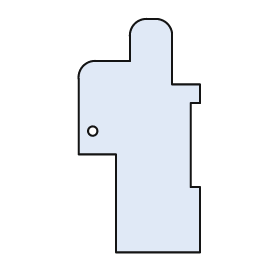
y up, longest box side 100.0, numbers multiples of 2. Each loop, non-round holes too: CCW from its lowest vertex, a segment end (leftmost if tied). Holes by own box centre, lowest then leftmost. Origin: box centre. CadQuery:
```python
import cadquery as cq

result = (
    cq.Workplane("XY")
    .moveTo(-10.0, -50.0)
    .lineTo(26.0, -50.0)
    .lineTo(26.0, -22.0)
    .lineTo(22.0, -22.0)
    .lineTo(22.0, 14.0)
    .lineTo(26.0, 14.0)
    .lineTo(26.0, 22.0)
    .lineTo(14.0, 22.0)
    .lineTo(14.0, 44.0)
    .threePointArc((12.0, 48.0), (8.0, 50.0))
    .lineTo(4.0, 50.0)
    .threePointArc((-2.0, 48.0), (-4.0, 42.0))
    .lineTo(-4.0, 32.0)
    .lineTo(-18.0, 32.0)
    .threePointArc((-24.0, 30.0), (-26.0, 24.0))
    .lineTo(-26.0, -8.0)
    .lineTo(-10.0, -8.0)
    .close()
    .moveTo(-20.0, 2.0)
    .circle(2.0)
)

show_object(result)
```